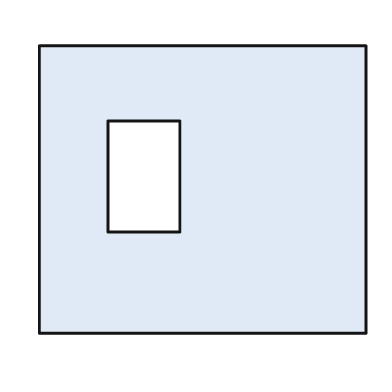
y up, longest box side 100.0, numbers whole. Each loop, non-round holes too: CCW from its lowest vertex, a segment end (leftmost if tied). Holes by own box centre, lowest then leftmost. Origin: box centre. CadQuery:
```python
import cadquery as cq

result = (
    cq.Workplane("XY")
    .moveTo(-50.0, -44.0)
    .lineTo(50.0, -44.0)
    .lineTo(50.0, 44.0)
    .lineTo(-50.0, 44.0)
    .close()
    .moveTo(-29.0, -13.0)
    .lineTo(-7.0, -13.0)
    .lineTo(-7.0, 21.0)
    .lineTo(-29.0, 21.0)
    .close()
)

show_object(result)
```